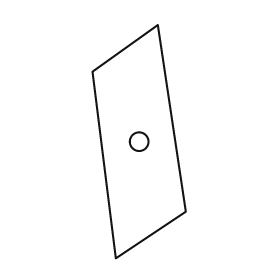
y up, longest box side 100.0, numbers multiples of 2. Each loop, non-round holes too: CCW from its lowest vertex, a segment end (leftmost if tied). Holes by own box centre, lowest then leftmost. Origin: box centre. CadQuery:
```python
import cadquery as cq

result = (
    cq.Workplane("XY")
    .moveTo(-10.0, -50.0)
    .lineTo(20.0, -30.0)
    .lineTo(8.0, 50.0)
    .lineTo(-20.0, 30.0)
    .close()
    .moveTo(0.0, 0.0)
    .circle(4.0)
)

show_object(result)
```